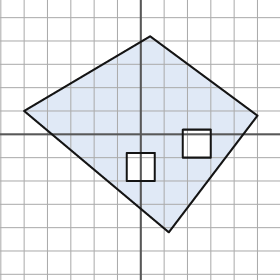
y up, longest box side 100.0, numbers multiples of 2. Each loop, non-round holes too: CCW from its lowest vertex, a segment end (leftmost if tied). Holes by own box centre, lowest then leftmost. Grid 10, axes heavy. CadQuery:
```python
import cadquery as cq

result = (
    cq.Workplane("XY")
    .moveTo(12.0, -42.0)
    .lineTo(50.0, 8.0)
    .lineTo(4.0, 42.0)
    .lineTo(-50.0, 10.0)
    .close()
    .moveTo(-6.0, -20.0)
    .lineTo(6.0, -20.0)
    .lineTo(6.0, -8.0)
    .lineTo(-6.0, -8.0)
    .close()
    .moveTo(18.0, -10.0)
    .lineTo(30.0, -10.0)
    .lineTo(30.0, 2.0)
    .lineTo(18.0, 2.0)
    .close()
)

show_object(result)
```